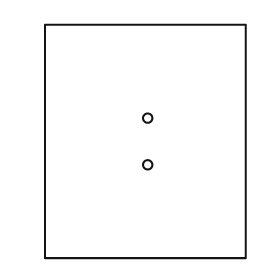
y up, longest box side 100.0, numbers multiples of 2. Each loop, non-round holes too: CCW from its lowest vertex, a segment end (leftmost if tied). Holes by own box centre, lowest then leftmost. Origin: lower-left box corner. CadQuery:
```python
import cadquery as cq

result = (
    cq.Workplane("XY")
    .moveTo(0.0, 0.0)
    .lineTo(86.0, 0.0)
    .lineTo(86.0, 100.0)
    .lineTo(0.0, 100.0)
    .close()
    .moveTo(44.0, 40.0)
    .circle(2.0)
    .moveTo(44.0, 60.0)
    .circle(2.0)
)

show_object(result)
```